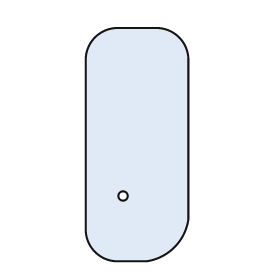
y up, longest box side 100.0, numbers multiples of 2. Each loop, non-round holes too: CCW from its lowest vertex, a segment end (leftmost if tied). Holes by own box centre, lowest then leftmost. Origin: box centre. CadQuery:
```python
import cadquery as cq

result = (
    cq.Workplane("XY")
    .moveTo(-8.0, -50.0)
    .lineTo(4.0, -50.0)
    .threePointArc((16.0, -44.0), (22.0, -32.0))
    .lineTo(22.0, 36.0)
    .threePointArc((18.0, 46.0), (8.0, 50.0))
    .lineTo(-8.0, 50.0)
    .threePointArc((-18.0, 46.0), (-22.0, 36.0))
    .lineTo(-22.0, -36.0)
    .threePointArc((-18.0, -46.0), (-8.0, -50.0))
    .close()
    .moveTo(-6.0, -22.0)
    .circle(2.0)
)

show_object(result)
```